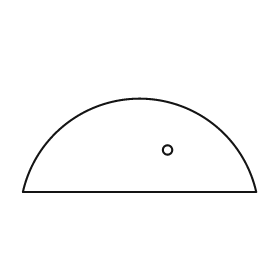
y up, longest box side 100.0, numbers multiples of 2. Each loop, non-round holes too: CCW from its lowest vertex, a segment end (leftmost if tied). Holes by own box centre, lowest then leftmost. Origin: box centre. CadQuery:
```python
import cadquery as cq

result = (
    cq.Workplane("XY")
    .moveTo(-50.0, -20.0)
    .lineTo(50.0, -20.0)
    .threePointArc((0.0, 20.0), (-50.0, -20.0))
    .close()
    .moveTo(12.0, -2.0)
    .circle(2.0)
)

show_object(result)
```